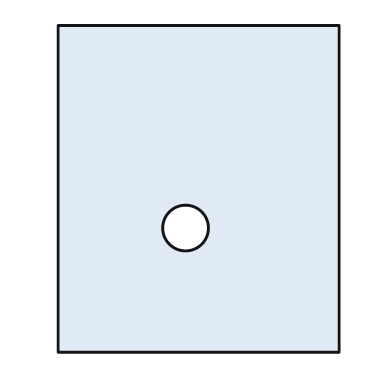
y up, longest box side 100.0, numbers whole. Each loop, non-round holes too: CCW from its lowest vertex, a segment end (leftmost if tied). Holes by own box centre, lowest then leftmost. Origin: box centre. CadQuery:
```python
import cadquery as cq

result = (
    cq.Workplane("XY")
    .moveTo(-43.0, -50.0)
    .lineTo(43.0, -50.0)
    .lineTo(43.0, 50.0)
    .lineTo(-43.0, 50.0)
    .close()
    .moveTo(-4.0, -12.0)
    .circle(7.0)
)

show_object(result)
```